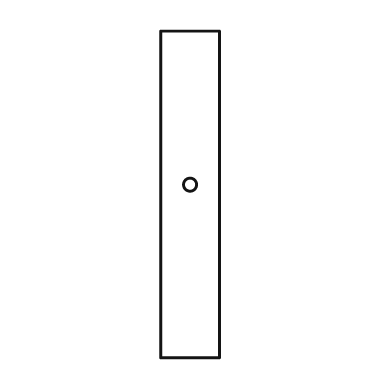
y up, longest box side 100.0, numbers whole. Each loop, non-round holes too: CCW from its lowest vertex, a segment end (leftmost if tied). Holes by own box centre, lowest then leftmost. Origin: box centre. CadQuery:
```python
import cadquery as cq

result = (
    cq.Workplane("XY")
    .moveTo(-9.0, -50.0)
    .lineTo(9.0, -50.0)
    .lineTo(9.0, 50.0)
    .lineTo(-9.0, 50.0)
    .close()
    .moveTo(0.0, 3.0)
    .circle(2.0)
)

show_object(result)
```